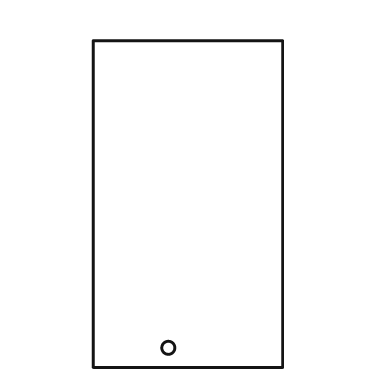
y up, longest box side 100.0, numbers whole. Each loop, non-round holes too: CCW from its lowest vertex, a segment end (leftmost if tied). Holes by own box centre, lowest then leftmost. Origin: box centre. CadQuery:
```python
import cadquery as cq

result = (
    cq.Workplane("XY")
    .moveTo(-29.0, -50.0)
    .lineTo(29.0, -50.0)
    .lineTo(29.0, 50.0)
    .lineTo(-29.0, 50.0)
    .close()
    .moveTo(-6.0, -44.0)
    .circle(2.0)
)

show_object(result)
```